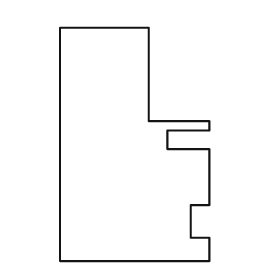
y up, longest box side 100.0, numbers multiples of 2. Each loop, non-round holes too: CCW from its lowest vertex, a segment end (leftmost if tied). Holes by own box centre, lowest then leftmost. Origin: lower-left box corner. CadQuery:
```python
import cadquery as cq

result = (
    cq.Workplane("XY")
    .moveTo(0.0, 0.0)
    .lineTo(64.0, 0.0)
    .lineTo(64.0, 10.0)
    .lineTo(56.0, 10.0)
    .lineTo(56.0, 24.0)
    .lineTo(64.0, 24.0)
    .lineTo(64.0, 48.0)
    .lineTo(46.0, 48.0)
    .lineTo(46.0, 56.0)
    .lineTo(64.0, 56.0)
    .lineTo(64.0, 60.0)
    .lineTo(38.0, 60.0)
    .lineTo(38.0, 100.0)
    .lineTo(0.0, 100.0)
    .close()
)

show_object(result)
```